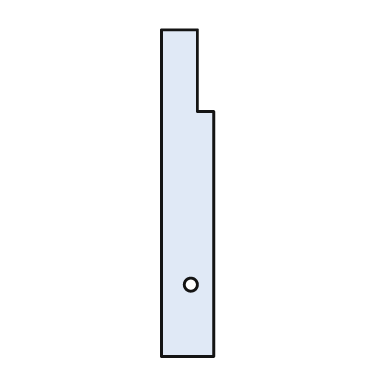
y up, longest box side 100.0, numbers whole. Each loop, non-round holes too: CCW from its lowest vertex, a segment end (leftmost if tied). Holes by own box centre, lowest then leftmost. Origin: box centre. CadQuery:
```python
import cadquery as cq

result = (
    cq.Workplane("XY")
    .moveTo(-8.0, -50.0)
    .lineTo(8.0, -50.0)
    .lineTo(8.0, 25.0)
    .lineTo(3.0, 25.0)
    .lineTo(3.0, 50.0)
    .lineTo(-8.0, 50.0)
    .close()
    .moveTo(1.0, -28.0)
    .circle(2.0)
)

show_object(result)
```